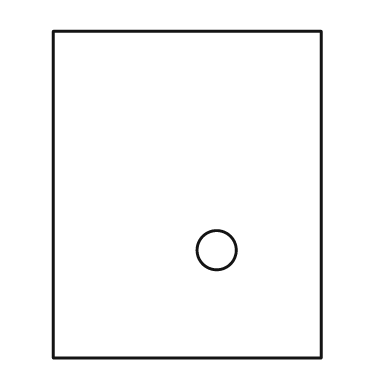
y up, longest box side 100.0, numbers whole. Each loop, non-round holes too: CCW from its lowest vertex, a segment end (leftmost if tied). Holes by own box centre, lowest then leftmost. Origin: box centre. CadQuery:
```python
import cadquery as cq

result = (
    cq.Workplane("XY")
    .moveTo(-41.0, -50.0)
    .lineTo(41.0, -50.0)
    .lineTo(41.0, 50.0)
    .lineTo(-41.0, 50.0)
    .close()
    .moveTo(9.0, -17.0)
    .circle(6.0)
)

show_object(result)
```